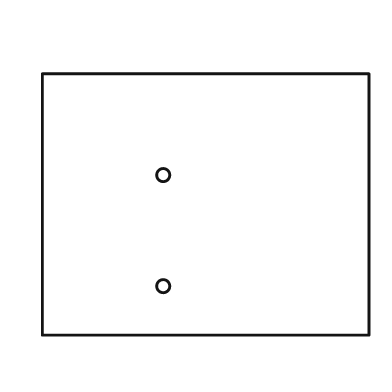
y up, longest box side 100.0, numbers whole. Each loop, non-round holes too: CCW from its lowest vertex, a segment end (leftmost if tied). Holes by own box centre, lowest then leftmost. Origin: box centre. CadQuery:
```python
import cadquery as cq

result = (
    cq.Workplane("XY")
    .moveTo(-50.0, -40.0)
    .lineTo(50.0, -40.0)
    .lineTo(50.0, 40.0)
    .lineTo(-50.0, 40.0)
    .close()
    .moveTo(-13.0, -25.0)
    .circle(2.0)
    .moveTo(-13.0, 9.0)
    .circle(2.0)
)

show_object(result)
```